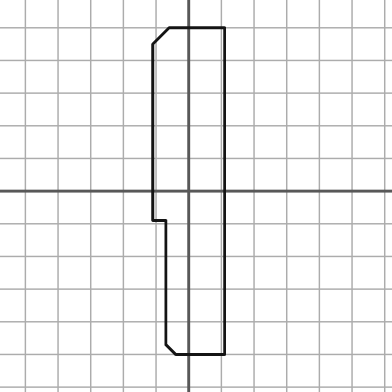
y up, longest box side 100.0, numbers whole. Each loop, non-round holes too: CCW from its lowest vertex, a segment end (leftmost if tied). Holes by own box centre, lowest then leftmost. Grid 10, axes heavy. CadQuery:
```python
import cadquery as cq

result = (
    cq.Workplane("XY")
    .moveTo(-4.0, -50.0)
    .lineTo(11.0, -50.0)
    .lineTo(11.0, 50.0)
    .lineTo(-6.0, 50.0)
    .lineTo(-11.0, 45.0)
    .lineTo(-11.0, -9.0)
    .lineTo(-7.0, -9.0)
    .lineTo(-7.0, -47.0)
    .close()
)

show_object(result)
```